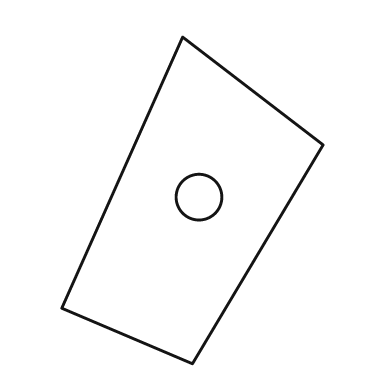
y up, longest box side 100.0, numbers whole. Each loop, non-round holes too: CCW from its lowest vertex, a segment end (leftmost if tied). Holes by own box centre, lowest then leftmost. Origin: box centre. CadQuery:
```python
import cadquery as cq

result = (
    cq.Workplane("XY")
    .moveTo(0.0, -50.0)
    .lineTo(40.0, 17.0)
    .lineTo(-3.0, 50.0)
    .lineTo(-40.0, -33.0)
    .close()
    .moveTo(2.0, 1.0)
    .circle(7.0)
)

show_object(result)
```